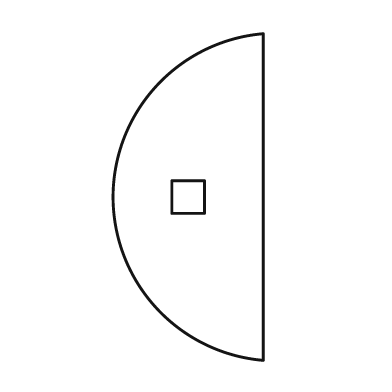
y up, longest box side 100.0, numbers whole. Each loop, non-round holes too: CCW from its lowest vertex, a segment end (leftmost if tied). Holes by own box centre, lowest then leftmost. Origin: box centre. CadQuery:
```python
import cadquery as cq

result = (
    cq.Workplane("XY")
    .moveTo(23.0, -50.0)
    .lineTo(23.0, 50.0)
    .threePointArc((-23.0, 0.0), (23.0, -50.0))
    .close()
    .moveTo(-5.0, -5.0)
    .lineTo(5.0, -5.0)
    .lineTo(5.0, 5.0)
    .lineTo(-5.0, 5.0)
    .close()
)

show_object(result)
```